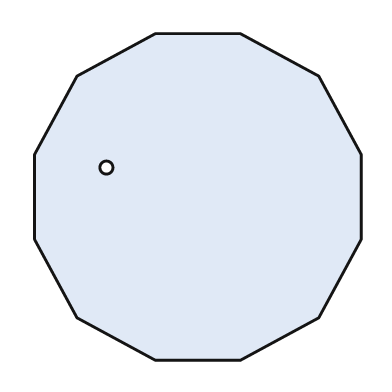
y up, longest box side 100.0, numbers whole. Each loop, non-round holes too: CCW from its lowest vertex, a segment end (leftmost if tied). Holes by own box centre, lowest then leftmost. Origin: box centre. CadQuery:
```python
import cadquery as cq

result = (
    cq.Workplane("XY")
    .moveTo(-13.0, -50.0)
    .lineTo(13.0, -50.0)
    .lineTo(37.0, -37.0)
    .lineTo(50.0, -13.0)
    .lineTo(50.0, 13.0)
    .lineTo(37.0, 37.0)
    .lineTo(13.0, 50.0)
    .lineTo(-13.0, 50.0)
    .lineTo(-37.0, 37.0)
    .lineTo(-50.0, 13.0)
    .lineTo(-50.0, -13.0)
    .lineTo(-37.0, -37.0)
    .close()
    .moveTo(-28.0, 9.0)
    .circle(2.0)
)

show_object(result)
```